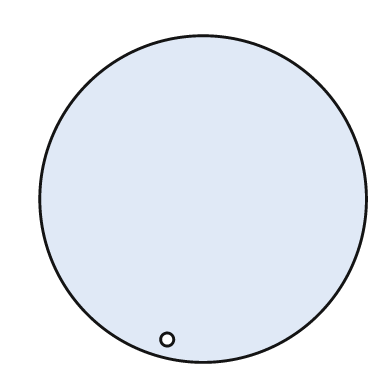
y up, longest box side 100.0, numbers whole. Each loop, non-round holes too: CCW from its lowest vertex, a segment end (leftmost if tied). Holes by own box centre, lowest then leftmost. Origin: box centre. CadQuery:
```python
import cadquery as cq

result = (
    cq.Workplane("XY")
    .moveTo(0.0, 0.0)
    .circle(50.0)
    .moveTo(-11.0, -43.0)
    .circle(2.0)
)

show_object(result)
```